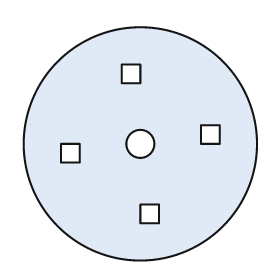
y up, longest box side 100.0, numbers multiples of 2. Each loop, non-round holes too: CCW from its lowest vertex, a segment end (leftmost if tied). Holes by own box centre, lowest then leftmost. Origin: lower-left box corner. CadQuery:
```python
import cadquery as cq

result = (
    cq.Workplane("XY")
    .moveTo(50.0, 50.0)
    .circle(50.0)
    .moveTo(50.0, 16.0)
    .lineTo(58.0, 16.0)
    .lineTo(58.0, 24.0)
    .lineTo(50.0, 24.0)
    .close()
    .moveTo(16.0, 42.0)
    .lineTo(24.0, 42.0)
    .lineTo(24.0, 50.0)
    .lineTo(16.0, 50.0)
    .close()
    .moveTo(50.0, 50.0)
    .circle(6.0)
    .moveTo(76.0, 50.0)
    .lineTo(84.0, 50.0)
    .lineTo(84.0, 58.0)
    .lineTo(76.0, 58.0)
    .close()
    .moveTo(42.0, 76.0)
    .lineTo(50.0, 76.0)
    .lineTo(50.0, 84.0)
    .lineTo(42.0, 84.0)
    .close()
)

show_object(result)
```